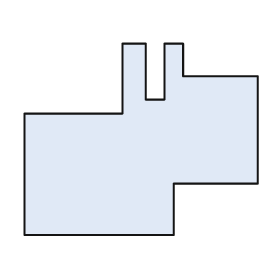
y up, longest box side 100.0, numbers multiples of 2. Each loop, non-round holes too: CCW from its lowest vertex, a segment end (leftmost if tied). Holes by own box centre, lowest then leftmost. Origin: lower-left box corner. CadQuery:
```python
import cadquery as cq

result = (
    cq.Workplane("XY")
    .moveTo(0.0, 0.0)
    .lineTo(64.0, 0.0)
    .lineTo(64.0, 22.0)
    .lineTo(100.0, 22.0)
    .lineTo(100.0, 68.0)
    .lineTo(68.0, 68.0)
    .lineTo(68.0, 82.0)
    .lineTo(60.0, 82.0)
    .lineTo(60.0, 58.0)
    .lineTo(52.0, 58.0)
    .lineTo(52.0, 82.0)
    .lineTo(42.0, 82.0)
    .lineTo(42.0, 52.0)
    .lineTo(0.0, 52.0)
    .close()
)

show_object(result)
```